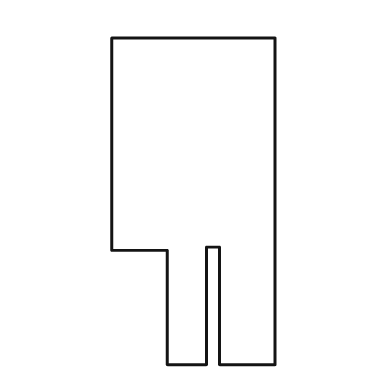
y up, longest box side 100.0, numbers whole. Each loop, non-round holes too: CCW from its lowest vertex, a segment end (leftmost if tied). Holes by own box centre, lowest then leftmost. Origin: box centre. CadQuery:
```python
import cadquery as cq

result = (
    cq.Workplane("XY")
    .moveTo(-8.0, -50.0)
    .lineTo(4.0, -50.0)
    .lineTo(4.0, -14.0)
    .lineTo(8.0, -14.0)
    .lineTo(8.0, -50.0)
    .lineTo(25.0, -50.0)
    .lineTo(25.0, 50.0)
    .lineTo(-25.0, 50.0)
    .lineTo(-25.0, -15.0)
    .lineTo(-8.0, -15.0)
    .close()
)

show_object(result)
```